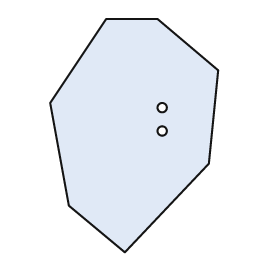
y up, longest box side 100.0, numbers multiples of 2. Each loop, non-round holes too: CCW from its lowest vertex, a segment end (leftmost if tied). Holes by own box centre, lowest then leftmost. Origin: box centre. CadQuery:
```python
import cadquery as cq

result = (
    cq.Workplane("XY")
    .moveTo(-4.0, -50.0)
    .lineTo(32.0, -12.0)
    .lineTo(36.0, 28.0)
    .lineTo(10.0, 50.0)
    .lineTo(-12.0, 50.0)
    .lineTo(-36.0, 14.0)
    .lineTo(-28.0, -30.0)
    .close()
    .moveTo(12.0, 2.0)
    .circle(2.0)
    .moveTo(12.0, 12.0)
    .circle(2.0)
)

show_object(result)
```